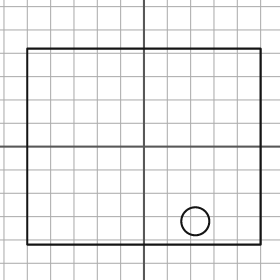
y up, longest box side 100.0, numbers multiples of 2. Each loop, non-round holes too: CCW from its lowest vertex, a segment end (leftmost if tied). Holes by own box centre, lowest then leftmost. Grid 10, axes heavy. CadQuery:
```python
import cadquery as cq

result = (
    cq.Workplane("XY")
    .moveTo(-50.0, -42.0)
    .lineTo(50.0, -42.0)
    .lineTo(50.0, 42.0)
    .lineTo(-50.0, 42.0)
    .close()
    .moveTo(22.0, -32.0)
    .circle(6.0)
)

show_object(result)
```